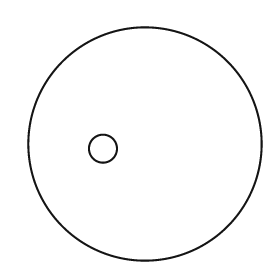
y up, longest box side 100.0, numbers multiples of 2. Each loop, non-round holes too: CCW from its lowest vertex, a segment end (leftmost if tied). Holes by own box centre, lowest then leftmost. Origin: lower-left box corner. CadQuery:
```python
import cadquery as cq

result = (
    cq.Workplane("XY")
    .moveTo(50.0, 50.0)
    .circle(50.0)
    .moveTo(32.0, 48.0)
    .circle(6.0)
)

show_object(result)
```